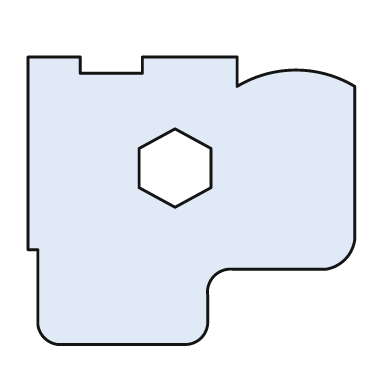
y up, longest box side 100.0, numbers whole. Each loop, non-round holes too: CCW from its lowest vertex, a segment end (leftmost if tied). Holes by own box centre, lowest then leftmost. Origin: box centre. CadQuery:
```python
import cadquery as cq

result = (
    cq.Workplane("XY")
    .moveTo(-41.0, -44.0)
    .lineTo(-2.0, -44.0)
    .threePointArc((3.0, -42.0), (5.0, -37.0))
    .lineTo(5.0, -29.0)
    .threePointArc((7.0, -23.0), (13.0, -21.0))
    .lineTo(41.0, -21.0)
    .threePointArc((47.0, -18.0), (50.0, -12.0))
    .lineTo(50.0, 35.0)
    .threePointArc((32.0, 40.0), (14.0, 35.0))
    .lineTo(14.0, 44.0)
    .lineTo(-15.0, 44.0)
    .lineTo(-15.0, 39.0)
    .lineTo(-34.0, 39.0)
    .lineTo(-34.0, 44.0)
    .lineTo(-50.0, 44.0)
    .lineTo(-50.0, -15.0)
    .lineTo(-47.0, -15.0)
    .lineTo(-47.0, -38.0)
    .threePointArc((-45.0, -42.0), (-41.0, -44.0))
    .close()
    .moveTo(-5.0, -2.0)
    .lineTo(6.0, 4.0)
    .lineTo(6.0, 16.0)
    .lineTo(-5.0, 22.0)
    .lineTo(-16.0, 16.0)
    .lineTo(-16.0, 4.0)
    .close()
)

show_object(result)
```